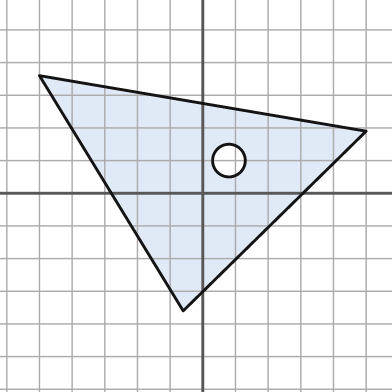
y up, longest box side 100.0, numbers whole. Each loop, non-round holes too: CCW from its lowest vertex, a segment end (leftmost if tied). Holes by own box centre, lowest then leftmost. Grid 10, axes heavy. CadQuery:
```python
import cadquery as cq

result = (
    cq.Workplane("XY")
    .moveTo(-6.0, -36.0)
    .lineTo(50.0, 19.0)
    .lineTo(-50.0, 36.0)
    .close()
    .moveTo(8.0, 10.0)
    .circle(5.0)
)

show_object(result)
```